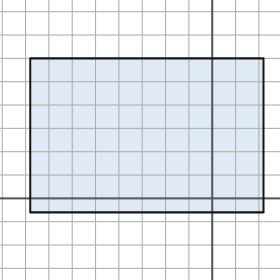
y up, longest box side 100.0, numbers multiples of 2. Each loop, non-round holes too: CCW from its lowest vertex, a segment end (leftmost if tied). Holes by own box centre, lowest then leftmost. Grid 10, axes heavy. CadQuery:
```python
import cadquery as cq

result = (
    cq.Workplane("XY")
    .moveTo(-78.0, -6.0)
    .lineTo(22.0, -6.0)
    .lineTo(22.0, 60.0)
    .lineTo(-78.0, 60.0)
    .close()
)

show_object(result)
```